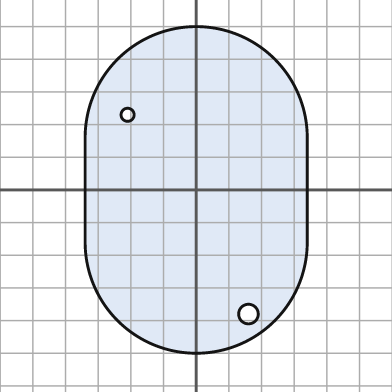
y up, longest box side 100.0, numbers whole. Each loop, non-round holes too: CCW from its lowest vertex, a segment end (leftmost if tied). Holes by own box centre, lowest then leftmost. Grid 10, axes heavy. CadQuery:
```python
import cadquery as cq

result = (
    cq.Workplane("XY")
    .moveTo(-34.0, -16.0)
    .threePointArc((0.0, -50.0), (34.0, -16.0))
    .lineTo(34.0, 16.0)
    .threePointArc((0.0, 50.0), (-34.0, 16.0))
    .close()
    .moveTo(16.0, -38.0)
    .circle(3.0)
    .moveTo(-21.0, 23.0)
    .circle(2.0)
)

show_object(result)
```